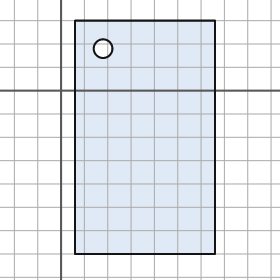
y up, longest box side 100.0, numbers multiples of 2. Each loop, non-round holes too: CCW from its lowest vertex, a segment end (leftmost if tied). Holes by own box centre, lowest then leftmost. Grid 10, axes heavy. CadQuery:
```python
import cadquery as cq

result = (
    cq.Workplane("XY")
    .moveTo(6.0, -70.0)
    .lineTo(66.0, -70.0)
    .lineTo(66.0, 30.0)
    .lineTo(6.0, 30.0)
    .close()
    .moveTo(18.0, 18.0)
    .circle(4.0)
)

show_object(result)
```